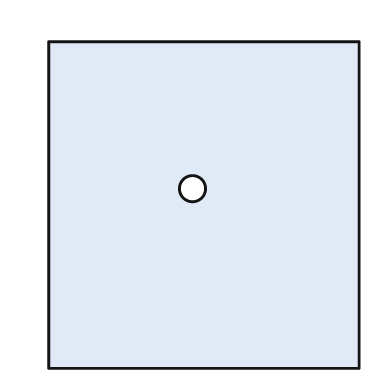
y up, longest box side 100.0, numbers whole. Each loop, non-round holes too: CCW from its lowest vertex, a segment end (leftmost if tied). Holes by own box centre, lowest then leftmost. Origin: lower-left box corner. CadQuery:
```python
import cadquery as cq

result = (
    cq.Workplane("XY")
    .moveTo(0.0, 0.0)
    .lineTo(95.0, 0.0)
    .lineTo(95.0, 100.0)
    .lineTo(0.0, 100.0)
    .close()
    .moveTo(44.0, 55.0)
    .circle(4.0)
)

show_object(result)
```